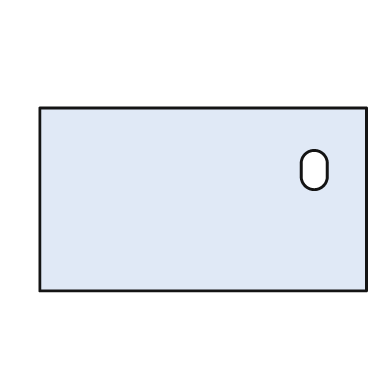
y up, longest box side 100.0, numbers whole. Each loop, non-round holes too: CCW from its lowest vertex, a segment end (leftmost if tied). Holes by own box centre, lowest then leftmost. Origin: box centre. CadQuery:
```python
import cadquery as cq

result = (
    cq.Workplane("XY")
    .moveTo(-50.0, -28.0)
    .lineTo(50.0, -28.0)
    .lineTo(50.0, 28.0)
    .lineTo(-50.0, 28.0)
    .close()
    .moveTo(30.0, 7.0)
    .threePointArc((34.0, 3.0), (38.0, 7.0))
    .lineTo(38.0, 11.0)
    .threePointArc((34.0, 15.0), (30.0, 11.0))
    .close()
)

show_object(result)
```